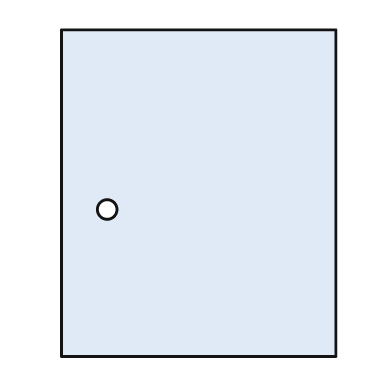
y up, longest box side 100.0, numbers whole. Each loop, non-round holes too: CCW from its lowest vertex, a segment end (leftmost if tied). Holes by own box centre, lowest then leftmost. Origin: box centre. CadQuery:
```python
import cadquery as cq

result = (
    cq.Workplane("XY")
    .moveTo(-42.0, -50.0)
    .lineTo(42.0, -50.0)
    .lineTo(42.0, 50.0)
    .lineTo(-42.0, 50.0)
    .close()
    .moveTo(-28.0, -5.0)
    .circle(3.0)
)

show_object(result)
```